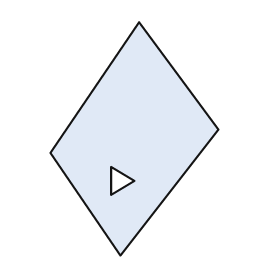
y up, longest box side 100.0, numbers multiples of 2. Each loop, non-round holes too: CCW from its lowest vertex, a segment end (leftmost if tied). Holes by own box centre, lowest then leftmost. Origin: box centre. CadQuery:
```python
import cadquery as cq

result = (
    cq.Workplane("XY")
    .moveTo(-6.0, -50.0)
    .lineTo(36.0, 4.0)
    .lineTo(2.0, 50.0)
    .lineTo(-36.0, -6.0)
    .close()
    .moveTo(-10.0, -24.0)
    .lineTo(0.0, -18.0)
    .lineTo(-10.0, -12.0)
    .close()
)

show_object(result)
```